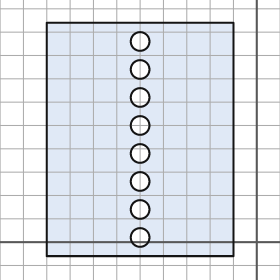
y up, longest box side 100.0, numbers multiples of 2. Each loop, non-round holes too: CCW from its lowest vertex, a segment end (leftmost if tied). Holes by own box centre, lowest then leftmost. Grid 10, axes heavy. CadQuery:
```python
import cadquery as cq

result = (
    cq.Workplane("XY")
    .moveTo(-90.0, -6.0)
    .lineTo(-10.0, -6.0)
    .lineTo(-10.0, 94.0)
    .lineTo(-90.0, 94.0)
    .close()
    .moveTo(-50.0, 2.0)
    .circle(4.0)
    .moveTo(-50.0, 14.0)
    .circle(4.0)
    .moveTo(-50.0, 26.0)
    .circle(4.0)
    .moveTo(-50.0, 38.0)
    .circle(4.0)
    .moveTo(-50.0, 50.0)
    .circle(4.0)
    .moveTo(-50.0, 62.0)
    .circle(4.0)
    .moveTo(-50.0, 74.0)
    .circle(4.0)
    .moveTo(-50.0, 86.0)
    .circle(4.0)
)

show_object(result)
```